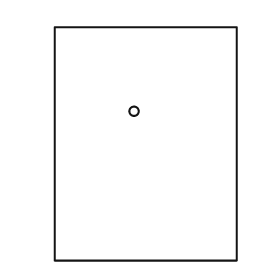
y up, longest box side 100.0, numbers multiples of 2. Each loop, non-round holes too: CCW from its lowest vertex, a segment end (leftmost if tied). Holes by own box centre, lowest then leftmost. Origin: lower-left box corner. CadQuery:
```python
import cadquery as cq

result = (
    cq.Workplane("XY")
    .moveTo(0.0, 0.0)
    .lineTo(78.0, 0.0)
    .lineTo(78.0, 100.0)
    .lineTo(0.0, 100.0)
    .close()
    .moveTo(34.0, 64.0)
    .circle(2.0)
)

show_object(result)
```